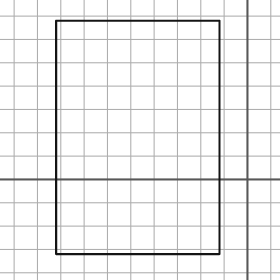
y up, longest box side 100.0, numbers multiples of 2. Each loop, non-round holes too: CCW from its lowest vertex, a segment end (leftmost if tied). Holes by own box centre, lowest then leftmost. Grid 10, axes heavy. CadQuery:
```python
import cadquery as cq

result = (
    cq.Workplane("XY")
    .moveTo(-82.0, -32.0)
    .lineTo(-12.0, -32.0)
    .lineTo(-12.0, 68.0)
    .lineTo(-82.0, 68.0)
    .close()
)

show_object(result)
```